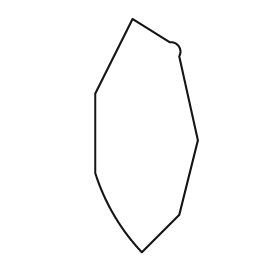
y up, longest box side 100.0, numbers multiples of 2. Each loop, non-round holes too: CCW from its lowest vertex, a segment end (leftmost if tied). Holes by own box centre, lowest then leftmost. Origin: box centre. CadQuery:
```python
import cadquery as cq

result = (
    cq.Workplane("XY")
    .moveTo(-2.0, -50.0)
    .lineTo(14.0, -34.0)
    .lineTo(22.0, -2.0)
    .lineTo(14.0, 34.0)
    .threePointArc((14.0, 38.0), (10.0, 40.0))
    .lineTo(-6.0, 50.0)
    .lineTo(-22.0, 18.0)
    .lineTo(-22.0, -16.0)
    .threePointArc((-14.0, -34.0), (-2.0, -50.0))
    .close()
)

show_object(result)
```